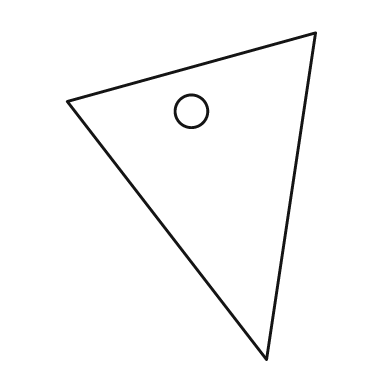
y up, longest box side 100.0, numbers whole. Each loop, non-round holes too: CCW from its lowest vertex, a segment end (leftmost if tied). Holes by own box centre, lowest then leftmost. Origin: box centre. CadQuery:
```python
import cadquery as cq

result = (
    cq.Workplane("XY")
    .moveTo(23.0, -50.0)
    .lineTo(38.0, 50.0)
    .lineTo(-38.0, 29.0)
    .close()
    .moveTo(0.0, 26.0)
    .circle(5.0)
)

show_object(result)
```